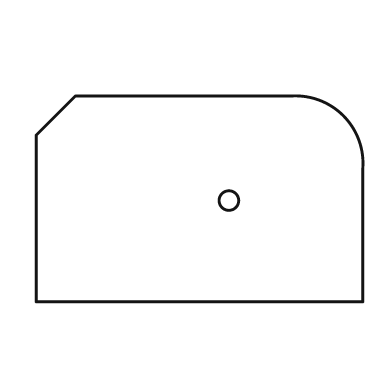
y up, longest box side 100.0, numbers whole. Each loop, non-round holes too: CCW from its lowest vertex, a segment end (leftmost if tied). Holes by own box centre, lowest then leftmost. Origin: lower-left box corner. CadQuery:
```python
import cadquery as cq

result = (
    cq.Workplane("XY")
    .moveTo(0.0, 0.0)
    .lineTo(100.0, 0.0)
    .lineTo(100.0, 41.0)
    .threePointArc((94.0, 57.0), (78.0, 63.0))
    .lineTo(12.0, 63.0)
    .lineTo(0.0, 51.0)
    .close()
    .moveTo(59.0, 31.0)
    .circle(3.0)
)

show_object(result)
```